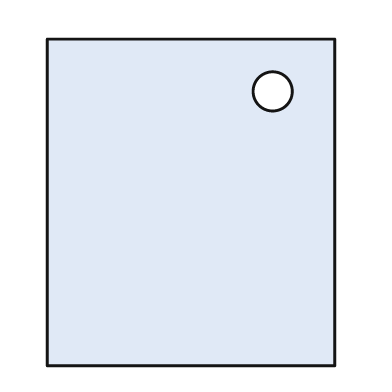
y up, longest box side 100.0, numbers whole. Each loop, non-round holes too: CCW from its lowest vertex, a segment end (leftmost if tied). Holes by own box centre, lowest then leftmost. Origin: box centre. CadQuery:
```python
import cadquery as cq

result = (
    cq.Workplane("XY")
    .moveTo(-44.0, -50.0)
    .lineTo(44.0, -50.0)
    .lineTo(44.0, 50.0)
    .lineTo(-44.0, 50.0)
    .close()
    .moveTo(25.0, 34.0)
    .circle(6.0)
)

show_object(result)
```